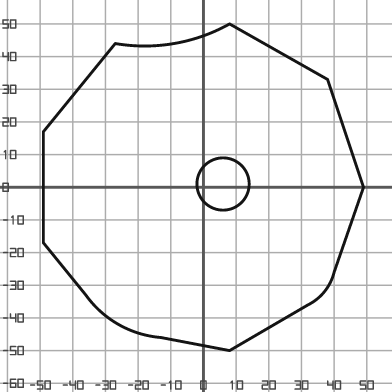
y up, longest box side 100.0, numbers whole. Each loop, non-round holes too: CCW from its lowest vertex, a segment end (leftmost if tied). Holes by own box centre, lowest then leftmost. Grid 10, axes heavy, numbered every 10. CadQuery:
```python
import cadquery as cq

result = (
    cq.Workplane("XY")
    .moveTo(8.0, -50.0)
    .lineTo(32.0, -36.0)
    .threePointArc((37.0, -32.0), (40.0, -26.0))
    .lineTo(49.0, 0.0)
    .lineTo(38.0, 33.0)
    .lineTo(8.0, 50.0)
    .threePointArc((-9.0, 44.0), (-27.0, 44.0))
    .lineTo(-49.0, 17.0)
    .lineTo(-49.0, -17.0)
    .lineTo(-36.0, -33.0)
    .threePointArc((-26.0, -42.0), (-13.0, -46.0))
    .close()
    .moveTo(6.0, 1.0)
    .circle(8.0)
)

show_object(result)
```